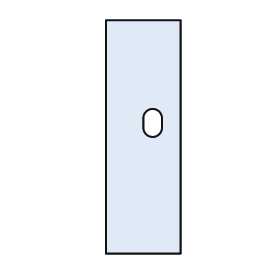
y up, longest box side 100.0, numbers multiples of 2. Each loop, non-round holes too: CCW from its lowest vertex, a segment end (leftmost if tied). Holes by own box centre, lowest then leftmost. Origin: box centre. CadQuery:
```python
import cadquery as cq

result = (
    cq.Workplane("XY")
    .moveTo(-16.0, -50.0)
    .lineTo(16.0, -50.0)
    .lineTo(16.0, 50.0)
    .lineTo(-16.0, 50.0)
    .close()
    .moveTo(0.0, 4.0)
    .threePointArc((4.0, 0.0), (8.0, 4.0))
    .lineTo(8.0, 8.0)
    .threePointArc((4.0, 12.0), (0.0, 8.0))
    .close()
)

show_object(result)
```